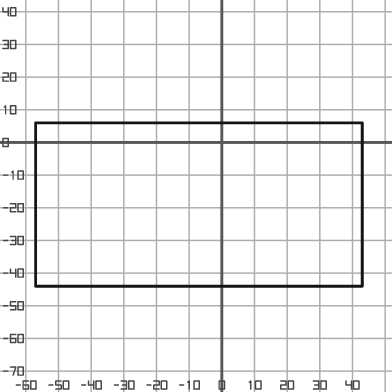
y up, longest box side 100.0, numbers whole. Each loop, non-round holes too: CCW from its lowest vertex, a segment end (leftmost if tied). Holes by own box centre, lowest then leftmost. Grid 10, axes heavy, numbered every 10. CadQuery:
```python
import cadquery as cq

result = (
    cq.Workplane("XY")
    .moveTo(-57.0, -44.0)
    .lineTo(43.0, -44.0)
    .lineTo(43.0, 6.0)
    .lineTo(-57.0, 6.0)
    .close()
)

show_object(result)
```